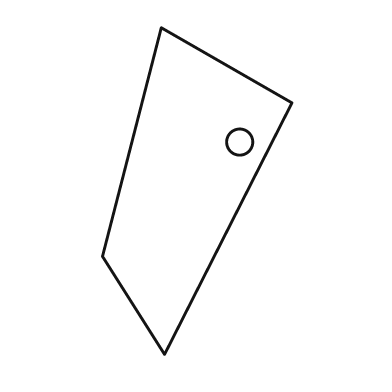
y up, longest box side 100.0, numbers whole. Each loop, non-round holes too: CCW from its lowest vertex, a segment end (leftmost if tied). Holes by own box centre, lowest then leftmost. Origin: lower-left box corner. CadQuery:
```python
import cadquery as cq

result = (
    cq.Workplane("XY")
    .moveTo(19.0, 0.0)
    .lineTo(58.0, 77.0)
    .lineTo(18.0, 100.0)
    .lineTo(0.0, 30.0)
    .close()
    .moveTo(42.0, 65.0)
    .circle(4.0)
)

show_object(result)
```